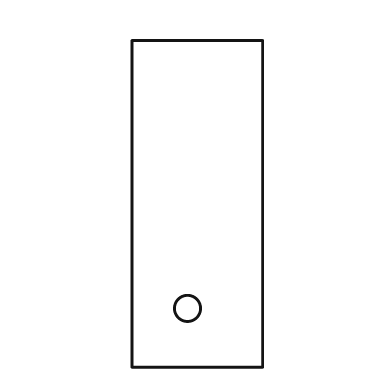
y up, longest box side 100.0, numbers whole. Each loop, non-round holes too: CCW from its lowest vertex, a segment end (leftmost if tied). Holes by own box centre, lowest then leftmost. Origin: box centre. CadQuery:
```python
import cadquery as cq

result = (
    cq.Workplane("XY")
    .moveTo(-20.0, -50.0)
    .lineTo(20.0, -50.0)
    .lineTo(20.0, 50.0)
    .lineTo(-20.0, 50.0)
    .close()
    .moveTo(-3.0, -32.0)
    .circle(4.0)
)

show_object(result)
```